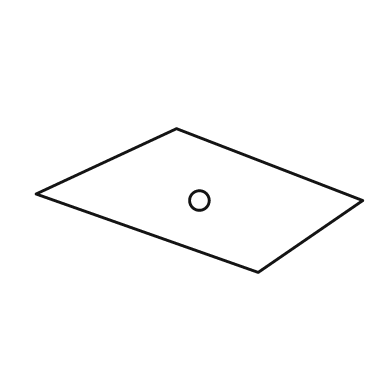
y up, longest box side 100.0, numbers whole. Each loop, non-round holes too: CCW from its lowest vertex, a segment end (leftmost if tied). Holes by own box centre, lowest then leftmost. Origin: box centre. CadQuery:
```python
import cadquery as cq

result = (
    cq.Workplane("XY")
    .moveTo(18.0, -22.0)
    .lineTo(50.0, 0.0)
    .lineTo(-7.0, 22.0)
    .lineTo(-50.0, 2.0)
    .close()
    .moveTo(0.0, 0.0)
    .circle(3.0)
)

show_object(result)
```